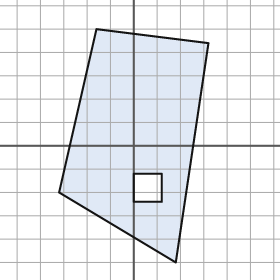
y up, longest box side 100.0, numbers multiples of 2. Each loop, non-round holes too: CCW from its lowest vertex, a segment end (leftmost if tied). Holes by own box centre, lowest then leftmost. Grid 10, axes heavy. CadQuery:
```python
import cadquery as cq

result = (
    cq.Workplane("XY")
    .moveTo(18.0, -50.0)
    .lineTo(32.0, 44.0)
    .lineTo(-16.0, 50.0)
    .lineTo(-32.0, -20.0)
    .close()
    .moveTo(0.0, -24.0)
    .lineTo(12.0, -24.0)
    .lineTo(12.0, -12.0)
    .lineTo(0.0, -12.0)
    .close()
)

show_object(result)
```